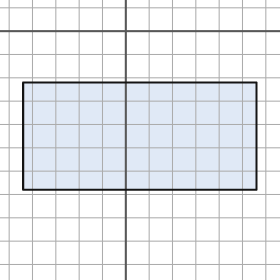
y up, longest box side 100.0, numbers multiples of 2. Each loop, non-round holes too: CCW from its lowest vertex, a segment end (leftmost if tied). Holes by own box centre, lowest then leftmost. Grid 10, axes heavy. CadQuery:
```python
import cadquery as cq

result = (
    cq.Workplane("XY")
    .moveTo(-44.0, -68.0)
    .lineTo(56.0, -68.0)
    .lineTo(56.0, -22.0)
    .lineTo(-44.0, -22.0)
    .close()
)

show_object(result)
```